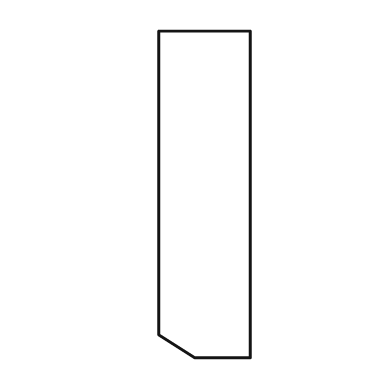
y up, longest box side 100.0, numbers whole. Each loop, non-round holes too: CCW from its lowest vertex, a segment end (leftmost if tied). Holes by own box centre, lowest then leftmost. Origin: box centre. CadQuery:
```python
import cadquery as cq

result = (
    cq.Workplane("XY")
    .moveTo(-3.0, -50.0)
    .lineTo(14.0, -50.0)
    .lineTo(14.0, 50.0)
    .lineTo(-14.0, 50.0)
    .lineTo(-14.0, -43.0)
    .close()
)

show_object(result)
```